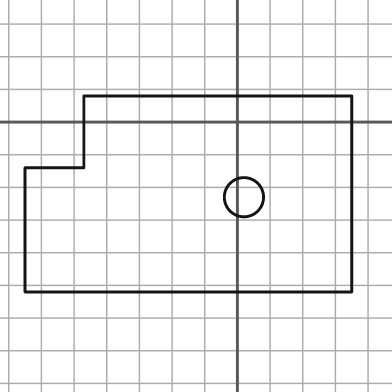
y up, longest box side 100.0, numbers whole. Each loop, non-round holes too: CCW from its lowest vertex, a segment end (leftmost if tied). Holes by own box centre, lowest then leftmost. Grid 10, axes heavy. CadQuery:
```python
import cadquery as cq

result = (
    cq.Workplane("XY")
    .moveTo(-65.0, -52.0)
    .lineTo(35.0, -52.0)
    .lineTo(35.0, 8.0)
    .lineTo(-47.0, 8.0)
    .lineTo(-47.0, -14.0)
    .lineTo(-65.0, -14.0)
    .close()
    .moveTo(2.0, -23.0)
    .circle(6.0)
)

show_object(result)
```